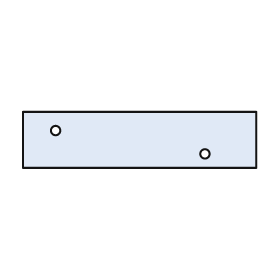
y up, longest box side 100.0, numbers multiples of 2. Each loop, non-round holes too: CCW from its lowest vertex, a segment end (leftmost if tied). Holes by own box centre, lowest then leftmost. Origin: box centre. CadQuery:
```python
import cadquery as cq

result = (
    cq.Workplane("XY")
    .moveTo(-50.0, -12.0)
    .lineTo(50.0, -12.0)
    .lineTo(50.0, 12.0)
    .lineTo(-50.0, 12.0)
    .close()
    .moveTo(28.0, -6.0)
    .circle(2.0)
    .moveTo(-36.0, 4.0)
    .circle(2.0)
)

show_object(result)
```